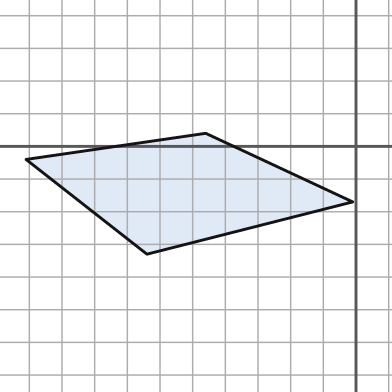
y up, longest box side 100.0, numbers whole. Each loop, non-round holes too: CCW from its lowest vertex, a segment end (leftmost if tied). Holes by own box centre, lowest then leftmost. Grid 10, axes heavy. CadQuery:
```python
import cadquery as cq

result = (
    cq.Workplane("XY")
    .moveTo(-64.0, -33.0)
    .lineTo(-1.0, -17.0)
    .lineTo(-46.0, 4.0)
    .lineTo(-101.0, -4.0)
    .close()
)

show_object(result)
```